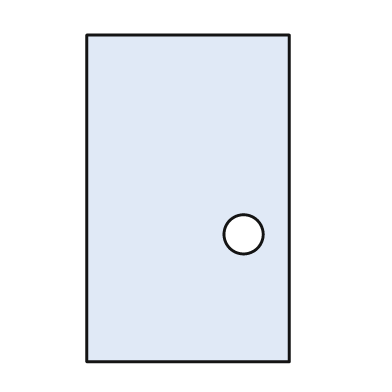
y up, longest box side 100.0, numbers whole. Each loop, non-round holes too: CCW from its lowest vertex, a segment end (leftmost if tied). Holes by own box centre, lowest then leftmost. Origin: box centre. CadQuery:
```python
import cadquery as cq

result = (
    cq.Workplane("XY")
    .moveTo(-31.0, -50.0)
    .lineTo(31.0, -50.0)
    .lineTo(31.0, 50.0)
    .lineTo(-31.0, 50.0)
    .close()
    .moveTo(17.0, -11.0)
    .circle(6.0)
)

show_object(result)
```